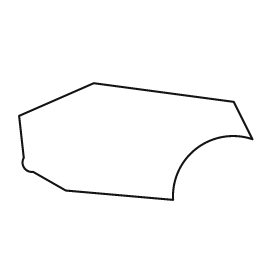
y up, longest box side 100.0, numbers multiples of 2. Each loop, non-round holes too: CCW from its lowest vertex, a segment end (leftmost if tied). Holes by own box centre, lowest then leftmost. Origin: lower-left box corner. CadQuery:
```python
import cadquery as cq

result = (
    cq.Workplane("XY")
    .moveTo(66.0, 0.0)
    .threePointArc((76.0, 22.0), (100.0, 26.0))
    .lineTo(92.0, 42.0)
    .lineTo(32.0, 50.0)
    .lineTo(0.0, 36.0)
    .lineTo(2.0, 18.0)
    .threePointArc((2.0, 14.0), (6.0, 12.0))
    .lineTo(20.0, 4.0)
    .close()
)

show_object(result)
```